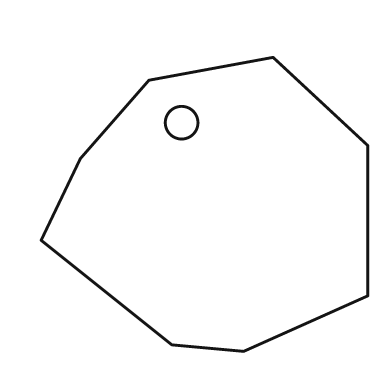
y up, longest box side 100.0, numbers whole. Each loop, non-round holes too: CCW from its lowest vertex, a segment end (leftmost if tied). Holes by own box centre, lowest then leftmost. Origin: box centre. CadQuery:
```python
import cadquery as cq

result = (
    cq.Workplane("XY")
    .moveTo(12.0, -45.0)
    .lineTo(50.0, -28.0)
    .lineTo(50.0, 18.0)
    .lineTo(21.0, 45.0)
    .lineTo(-17.0, 38.0)
    .lineTo(-38.0, 14.0)
    .lineTo(-50.0, -11.0)
    .lineTo(-10.0, -43.0)
    .close()
    .moveTo(-7.0, 25.0)
    .circle(5.0)
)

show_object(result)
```